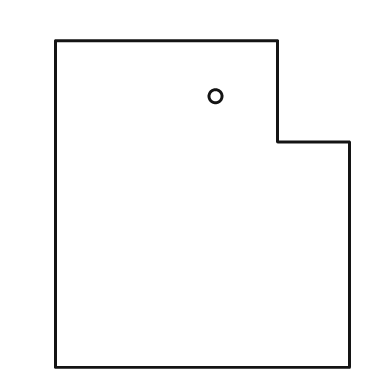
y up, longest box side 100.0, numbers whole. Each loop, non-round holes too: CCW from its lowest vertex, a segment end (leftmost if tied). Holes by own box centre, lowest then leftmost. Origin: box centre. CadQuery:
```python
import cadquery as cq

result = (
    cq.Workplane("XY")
    .moveTo(-45.0, -50.0)
    .lineTo(45.0, -50.0)
    .lineTo(45.0, 19.0)
    .lineTo(23.0, 19.0)
    .lineTo(23.0, 50.0)
    .lineTo(-45.0, 50.0)
    .close()
    .moveTo(4.0, 33.0)
    .circle(2.0)
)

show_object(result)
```